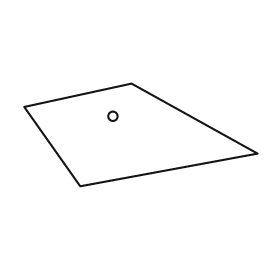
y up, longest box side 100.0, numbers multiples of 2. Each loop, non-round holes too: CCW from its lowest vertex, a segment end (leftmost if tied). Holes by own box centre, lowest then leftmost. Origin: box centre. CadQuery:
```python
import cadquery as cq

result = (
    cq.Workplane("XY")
    .moveTo(-26.0, -22.0)
    .lineTo(50.0, -8.0)
    .lineTo(-4.0, 22.0)
    .lineTo(-50.0, 12.0)
    .close()
    .moveTo(-12.0, 8.0)
    .circle(2.0)
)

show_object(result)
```